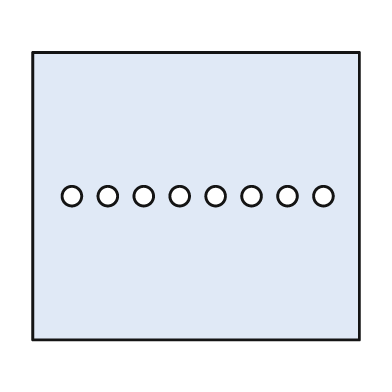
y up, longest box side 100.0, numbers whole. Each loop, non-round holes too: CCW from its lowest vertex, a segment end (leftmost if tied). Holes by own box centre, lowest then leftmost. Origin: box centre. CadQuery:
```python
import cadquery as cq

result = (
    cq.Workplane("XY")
    .moveTo(-50.0, -44.0)
    .lineTo(50.0, -44.0)
    .lineTo(50.0, 44.0)
    .lineTo(-50.0, 44.0)
    .close()
    .moveTo(-38.0, 0.0)
    .circle(3.0)
    .moveTo(-27.0, 0.0)
    .circle(3.0)
    .moveTo(-16.0, 0.0)
    .circle(3.0)
    .moveTo(-5.0, 0.0)
    .circle(3.0)
    .moveTo(6.0, 0.0)
    .circle(3.0)
    .moveTo(17.0, 0.0)
    .circle(3.0)
    .moveTo(28.0, 0.0)
    .circle(3.0)
    .moveTo(39.0, 0.0)
    .circle(3.0)
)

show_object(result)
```